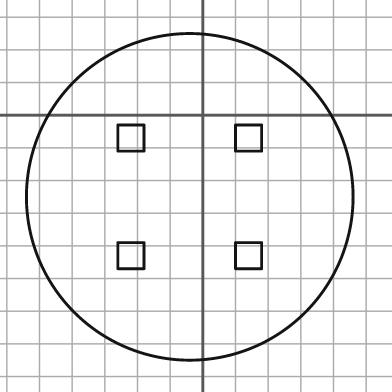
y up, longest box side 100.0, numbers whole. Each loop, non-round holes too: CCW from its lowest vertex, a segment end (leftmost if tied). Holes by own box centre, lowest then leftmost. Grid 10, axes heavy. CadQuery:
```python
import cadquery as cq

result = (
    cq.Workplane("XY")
    .moveTo(-4.0, -25.0)
    .circle(50.0)
    .moveTo(-26.0, -47.0)
    .lineTo(-18.0, -47.0)
    .lineTo(-18.0, -39.0)
    .lineTo(-26.0, -39.0)
    .close()
    .moveTo(10.0, -47.0)
    .lineTo(18.0, -47.0)
    .lineTo(18.0, -39.0)
    .lineTo(10.0, -39.0)
    .close()
    .moveTo(-26.0, -11.0)
    .lineTo(-18.0, -11.0)
    .lineTo(-18.0, -3.0)
    .lineTo(-26.0, -3.0)
    .close()
    .moveTo(10.0, -11.0)
    .lineTo(18.0, -11.0)
    .lineTo(18.0, -3.0)
    .lineTo(10.0, -3.0)
    .close()
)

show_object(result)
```